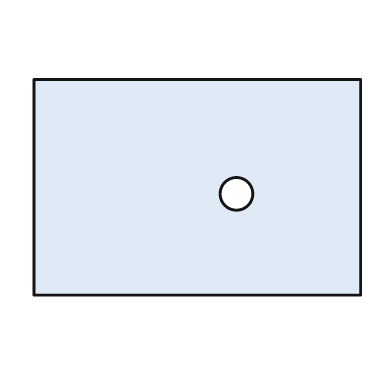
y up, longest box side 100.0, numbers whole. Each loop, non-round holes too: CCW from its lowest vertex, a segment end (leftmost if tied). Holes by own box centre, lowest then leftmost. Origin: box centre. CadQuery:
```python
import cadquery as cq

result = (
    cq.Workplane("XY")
    .moveTo(-50.0, -33.0)
    .lineTo(50.0, -33.0)
    .lineTo(50.0, 33.0)
    .lineTo(-50.0, 33.0)
    .close()
    .moveTo(12.0, -2.0)
    .circle(5.0)
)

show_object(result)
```